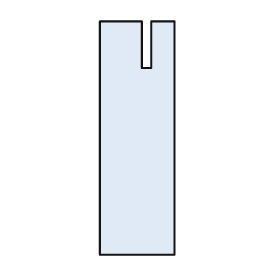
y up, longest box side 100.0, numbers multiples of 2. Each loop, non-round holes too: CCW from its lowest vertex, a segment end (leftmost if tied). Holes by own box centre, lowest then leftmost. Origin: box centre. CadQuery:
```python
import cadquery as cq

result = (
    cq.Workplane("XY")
    .moveTo(-16.0, -50.0)
    .lineTo(16.0, -50.0)
    .lineTo(16.0, 50.0)
    .lineTo(6.0, 50.0)
    .lineTo(6.0, 30.0)
    .lineTo(2.0, 30.0)
    .lineTo(2.0, 50.0)
    .lineTo(-16.0, 50.0)
    .close()
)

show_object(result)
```